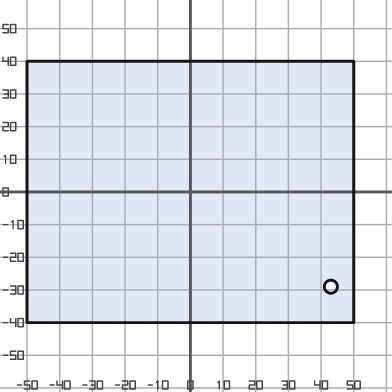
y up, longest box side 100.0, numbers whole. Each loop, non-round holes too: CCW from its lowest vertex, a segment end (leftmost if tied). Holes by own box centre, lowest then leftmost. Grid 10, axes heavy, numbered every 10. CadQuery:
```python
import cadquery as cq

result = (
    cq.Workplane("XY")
    .moveTo(-50.0, -40.0)
    .lineTo(50.0, -40.0)
    .lineTo(50.0, 40.0)
    .lineTo(-50.0, 40.0)
    .close()
    .moveTo(43.0, -29.0)
    .circle(2.0)
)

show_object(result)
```